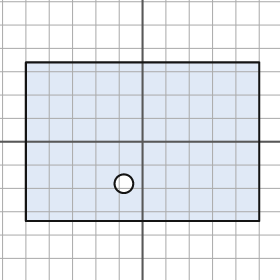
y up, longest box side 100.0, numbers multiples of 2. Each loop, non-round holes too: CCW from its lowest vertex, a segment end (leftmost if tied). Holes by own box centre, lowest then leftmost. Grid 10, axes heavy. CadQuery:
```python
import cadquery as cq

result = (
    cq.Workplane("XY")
    .moveTo(-50.0, -34.0)
    .lineTo(50.0, -34.0)
    .lineTo(50.0, 34.0)
    .lineTo(-50.0, 34.0)
    .close()
    .moveTo(-8.0, -18.0)
    .circle(4.0)
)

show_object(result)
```